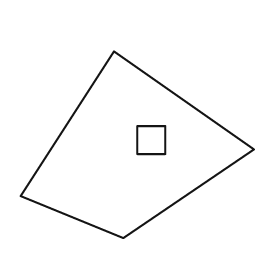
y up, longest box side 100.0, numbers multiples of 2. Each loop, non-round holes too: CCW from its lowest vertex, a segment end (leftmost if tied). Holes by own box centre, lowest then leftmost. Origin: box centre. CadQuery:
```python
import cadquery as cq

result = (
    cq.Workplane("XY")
    .moveTo(-6.0, -40.0)
    .lineTo(50.0, -2.0)
    .lineTo(-10.0, 40.0)
    .lineTo(-50.0, -22.0)
    .close()
    .moveTo(0.0, -4.0)
    .lineTo(12.0, -4.0)
    .lineTo(12.0, 8.0)
    .lineTo(0.0, 8.0)
    .close()
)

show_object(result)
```